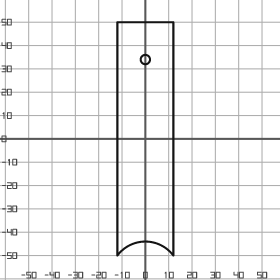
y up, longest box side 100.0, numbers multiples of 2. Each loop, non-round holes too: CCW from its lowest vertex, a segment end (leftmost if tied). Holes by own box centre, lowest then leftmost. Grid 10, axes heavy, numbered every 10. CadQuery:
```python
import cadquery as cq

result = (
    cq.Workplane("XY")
    .moveTo(-12.0, -50.0)
    .threePointArc((0.0, -44.0), (12.0, -50.0))
    .lineTo(12.0, 50.0)
    .lineTo(-12.0, 50.0)
    .close()
    .moveTo(0.0, 34.0)
    .circle(2.0)
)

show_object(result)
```